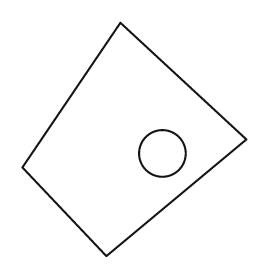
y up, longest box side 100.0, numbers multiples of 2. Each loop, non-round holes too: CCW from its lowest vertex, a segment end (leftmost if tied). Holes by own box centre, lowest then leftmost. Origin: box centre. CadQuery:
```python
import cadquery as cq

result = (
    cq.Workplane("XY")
    .moveTo(-12.0, -50.0)
    .lineTo(48.0, 0.0)
    .lineTo(-6.0, 50.0)
    .lineTo(-48.0, -12.0)
    .close()
    .moveTo(12.0, -6.0)
    .circle(10.0)
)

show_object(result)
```